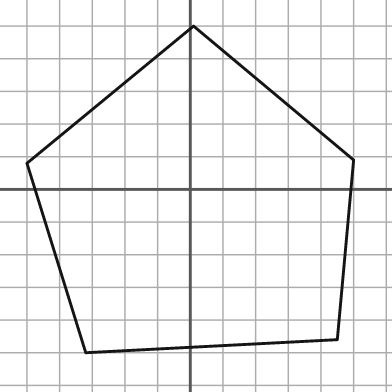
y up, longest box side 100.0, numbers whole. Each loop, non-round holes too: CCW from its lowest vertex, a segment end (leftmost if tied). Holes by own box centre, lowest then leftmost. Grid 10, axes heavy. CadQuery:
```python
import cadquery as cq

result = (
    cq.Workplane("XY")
    .moveTo(-32.0, -50.0)
    .lineTo(45.0, -46.0)
    .lineTo(50.0, 9.0)
    .lineTo(1.0, 50.0)
    .lineTo(-50.0, 8.0)
    .close()
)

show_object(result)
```